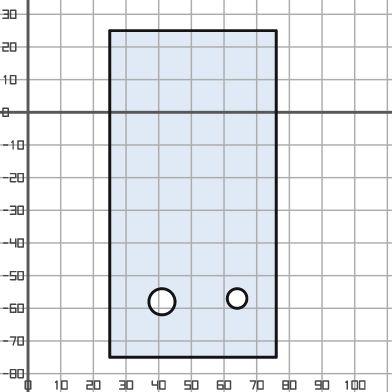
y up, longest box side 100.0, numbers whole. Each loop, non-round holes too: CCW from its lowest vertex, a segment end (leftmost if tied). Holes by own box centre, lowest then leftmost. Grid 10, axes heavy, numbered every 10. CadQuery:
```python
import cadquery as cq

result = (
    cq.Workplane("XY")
    .moveTo(25.0, -75.0)
    .lineTo(76.0, -75.0)
    .lineTo(76.0, 25.0)
    .lineTo(25.0, 25.0)
    .close()
    .moveTo(41.0, -58.0)
    .circle(4.0)
    .moveTo(64.0, -57.0)
    .circle(3.0)
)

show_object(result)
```